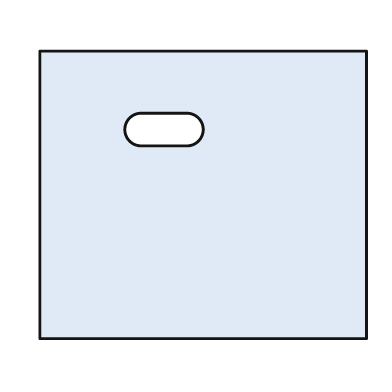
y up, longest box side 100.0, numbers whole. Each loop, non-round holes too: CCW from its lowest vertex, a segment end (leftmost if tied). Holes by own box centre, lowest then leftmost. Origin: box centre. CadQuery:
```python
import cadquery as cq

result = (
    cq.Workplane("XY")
    .moveTo(-50.0, -44.0)
    .lineTo(50.0, -44.0)
    .lineTo(50.0, 44.0)
    .lineTo(-50.0, 44.0)
    .close()
    .moveTo(-19.0, 15.0)
    .lineTo(-5.0, 15.0)
    .threePointArc((0.0, 20.0), (-5.0, 25.0))
    .lineTo(-19.0, 25.0)
    .threePointArc((-24.0, 20.0), (-19.0, 15.0))
    .close()
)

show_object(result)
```